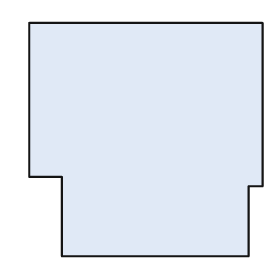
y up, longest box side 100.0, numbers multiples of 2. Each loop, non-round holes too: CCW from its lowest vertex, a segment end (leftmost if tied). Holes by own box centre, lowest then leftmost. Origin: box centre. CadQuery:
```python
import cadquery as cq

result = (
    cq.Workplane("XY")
    .moveTo(-36.0, -50.0)
    .lineTo(44.0, -50.0)
    .lineTo(44.0, -20.0)
    .lineTo(50.0, -20.0)
    .lineTo(50.0, 50.0)
    .lineTo(-50.0, 50.0)
    .lineTo(-50.0, -16.0)
    .lineTo(-36.0, -16.0)
    .close()
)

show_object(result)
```